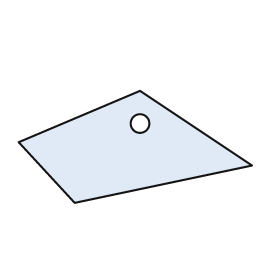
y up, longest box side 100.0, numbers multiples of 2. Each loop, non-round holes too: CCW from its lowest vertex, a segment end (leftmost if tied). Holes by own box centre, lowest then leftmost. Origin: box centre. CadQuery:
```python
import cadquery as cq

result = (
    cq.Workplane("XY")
    .moveTo(-26.0, -24.0)
    .lineTo(50.0, -8.0)
    .lineTo(2.0, 24.0)
    .lineTo(-50.0, 2.0)
    .close()
    .moveTo(2.0, 10.0)
    .circle(4.0)
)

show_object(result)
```